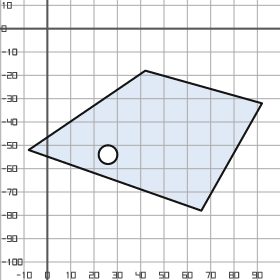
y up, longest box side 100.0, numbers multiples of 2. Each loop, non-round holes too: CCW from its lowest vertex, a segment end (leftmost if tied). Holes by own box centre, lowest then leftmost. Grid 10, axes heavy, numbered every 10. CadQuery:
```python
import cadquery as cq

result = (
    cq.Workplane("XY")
    .moveTo(66.0, -78.0)
    .lineTo(92.0, -32.0)
    .lineTo(42.0, -18.0)
    .lineTo(-8.0, -52.0)
    .close()
    .moveTo(26.0, -54.0)
    .circle(4.0)
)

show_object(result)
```